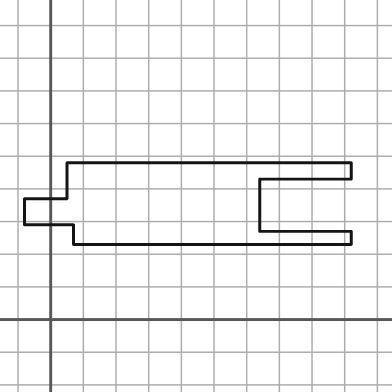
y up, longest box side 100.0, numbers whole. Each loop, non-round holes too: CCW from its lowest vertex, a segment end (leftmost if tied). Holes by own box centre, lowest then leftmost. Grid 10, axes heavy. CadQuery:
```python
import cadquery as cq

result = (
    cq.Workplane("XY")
    .moveTo(7.0, 23.0)
    .lineTo(92.0, 23.0)
    .lineTo(92.0, 27.0)
    .lineTo(64.0, 27.0)
    .lineTo(64.0, 43.0)
    .lineTo(92.0, 43.0)
    .lineTo(92.0, 48.0)
    .lineTo(5.0, 48.0)
    .lineTo(5.0, 37.0)
    .lineTo(-8.0, 37.0)
    .lineTo(-8.0, 29.0)
    .lineTo(7.0, 29.0)
    .close()
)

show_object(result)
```